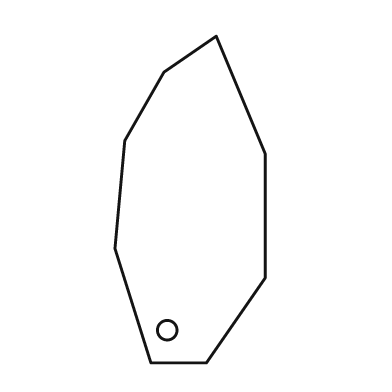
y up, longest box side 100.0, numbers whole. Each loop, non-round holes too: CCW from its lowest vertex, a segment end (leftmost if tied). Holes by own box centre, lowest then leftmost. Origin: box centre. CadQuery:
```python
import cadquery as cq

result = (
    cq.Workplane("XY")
    .moveTo(-12.0, -50.0)
    .lineTo(5.0, -50.0)
    .lineTo(23.0, -24.0)
    .lineTo(23.0, 14.0)
    .lineTo(8.0, 50.0)
    .lineTo(-8.0, 39.0)
    .lineTo(-20.0, 18.0)
    .lineTo(-23.0, -15.0)
    .close()
    .moveTo(-7.0, -40.0)
    .circle(3.0)
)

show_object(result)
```